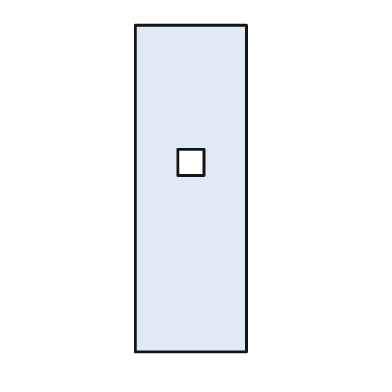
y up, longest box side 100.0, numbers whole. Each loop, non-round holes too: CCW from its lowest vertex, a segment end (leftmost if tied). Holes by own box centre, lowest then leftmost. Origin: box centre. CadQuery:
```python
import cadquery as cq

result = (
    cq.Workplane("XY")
    .moveTo(-17.0, -50.0)
    .lineTo(17.0, -50.0)
    .lineTo(17.0, 50.0)
    .lineTo(-17.0, 50.0)
    .close()
    .moveTo(-4.0, 4.0)
    .lineTo(4.0, 4.0)
    .lineTo(4.0, 12.0)
    .lineTo(-4.0, 12.0)
    .close()
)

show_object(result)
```